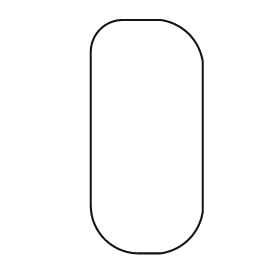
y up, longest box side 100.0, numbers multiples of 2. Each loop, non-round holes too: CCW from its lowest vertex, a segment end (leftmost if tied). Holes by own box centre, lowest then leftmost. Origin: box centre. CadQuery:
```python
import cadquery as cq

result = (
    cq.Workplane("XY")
    .moveTo(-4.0, -50.0)
    .lineTo(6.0, -50.0)
    .threePointArc((18.0, -44.0), (24.0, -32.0))
    .lineTo(24.0, 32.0)
    .threePointArc((18.0, 44.0), (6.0, 50.0))
    .lineTo(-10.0, 50.0)
    .threePointArc((-20.0, 46.0), (-24.0, 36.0))
    .lineTo(-24.0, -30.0)
    .threePointArc((-18.0, -44.0), (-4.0, -50.0))
    .close()
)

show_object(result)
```